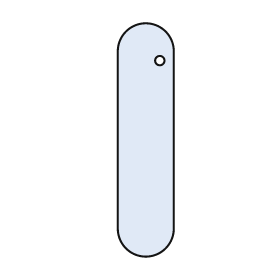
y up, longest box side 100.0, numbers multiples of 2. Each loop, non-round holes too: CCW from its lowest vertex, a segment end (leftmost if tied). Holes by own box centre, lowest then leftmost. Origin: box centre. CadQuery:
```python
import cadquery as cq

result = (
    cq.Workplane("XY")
    .moveTo(-12.0, -38.0)
    .threePointArc((0.0, -50.0), (12.0, -38.0))
    .lineTo(12.0, 38.0)
    .threePointArc((0.0, 50.0), (-12.0, 38.0))
    .close()
    .moveTo(6.0, 34.0)
    .circle(2.0)
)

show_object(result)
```